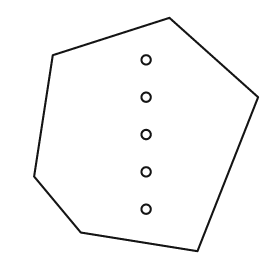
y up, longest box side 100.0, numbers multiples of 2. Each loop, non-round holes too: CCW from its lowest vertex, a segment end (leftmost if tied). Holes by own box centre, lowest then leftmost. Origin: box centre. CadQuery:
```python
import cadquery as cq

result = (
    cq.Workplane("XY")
    .moveTo(22.0, -50.0)
    .lineTo(48.0, 16.0)
    .lineTo(10.0, 50.0)
    .lineTo(-40.0, 34.0)
    .lineTo(-48.0, -18.0)
    .lineTo(-28.0, -42.0)
    .close()
    .moveTo(0.0, -32.0)
    .circle(2.0)
    .moveTo(0.0, -16.0)
    .circle(2.0)
    .moveTo(0.0, 0.0)
    .circle(2.0)
    .moveTo(0.0, 16.0)
    .circle(2.0)
    .moveTo(0.0, 32.0)
    .circle(2.0)
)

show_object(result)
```